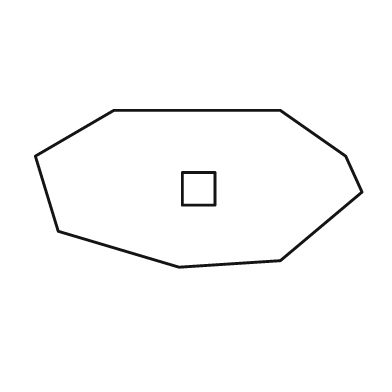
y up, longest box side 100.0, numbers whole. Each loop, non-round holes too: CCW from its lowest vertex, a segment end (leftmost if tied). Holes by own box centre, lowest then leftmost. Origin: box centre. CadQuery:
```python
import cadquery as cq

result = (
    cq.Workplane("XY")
    .moveTo(-6.0, -24.0)
    .lineTo(25.0, -22.0)
    .lineTo(50.0, -1.0)
    .lineTo(45.0, 10.0)
    .lineTo(25.0, 24.0)
    .lineTo(-26.0, 24.0)
    .lineTo(-50.0, 10.0)
    .lineTo(-43.0, -13.0)
    .close()
    .moveTo(-5.0, -5.0)
    .lineTo(5.0, -5.0)
    .lineTo(5.0, 5.0)
    .lineTo(-5.0, 5.0)
    .close()
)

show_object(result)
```